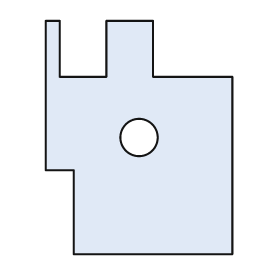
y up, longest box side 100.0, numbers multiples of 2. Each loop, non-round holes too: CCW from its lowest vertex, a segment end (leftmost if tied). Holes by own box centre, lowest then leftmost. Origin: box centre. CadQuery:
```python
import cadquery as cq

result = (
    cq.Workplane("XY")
    .moveTo(-28.0, -50.0)
    .lineTo(40.0, -50.0)
    .lineTo(40.0, 26.0)
    .lineTo(6.0, 26.0)
    .lineTo(6.0, 50.0)
    .lineTo(-14.0, 50.0)
    .lineTo(-14.0, 26.0)
    .lineTo(-34.0, 26.0)
    .lineTo(-34.0, 50.0)
    .lineTo(-40.0, 50.0)
    .lineTo(-40.0, -14.0)
    .lineTo(-28.0, -14.0)
    .close()
    .moveTo(0.0, 0.0)
    .circle(8.0)
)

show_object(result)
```